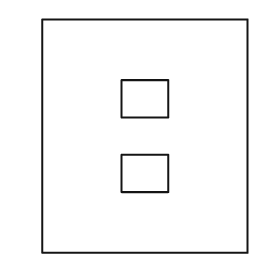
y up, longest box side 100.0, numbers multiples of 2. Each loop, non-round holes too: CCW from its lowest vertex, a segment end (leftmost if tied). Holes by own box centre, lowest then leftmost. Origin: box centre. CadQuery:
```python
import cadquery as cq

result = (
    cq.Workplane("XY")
    .moveTo(-44.0, -50.0)
    .lineTo(44.0, -50.0)
    .lineTo(44.0, 50.0)
    .lineTo(-44.0, 50.0)
    .close()
    .moveTo(-10.0, -24.0)
    .lineTo(10.0, -24.0)
    .lineTo(10.0, -8.0)
    .lineTo(-10.0, -8.0)
    .close()
    .moveTo(-10.0, 8.0)
    .lineTo(10.0, 8.0)
    .lineTo(10.0, 24.0)
    .lineTo(-10.0, 24.0)
    .close()
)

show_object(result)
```